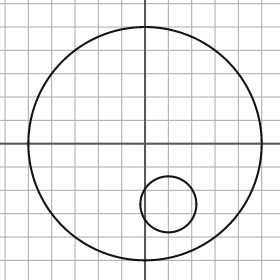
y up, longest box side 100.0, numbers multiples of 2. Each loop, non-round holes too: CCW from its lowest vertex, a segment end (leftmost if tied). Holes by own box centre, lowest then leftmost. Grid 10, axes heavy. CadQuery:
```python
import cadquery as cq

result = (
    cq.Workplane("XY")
    .moveTo(0.0, 0.0)
    .circle(50.0)
    .moveTo(10.0, -26.0)
    .circle(12.0)
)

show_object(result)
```